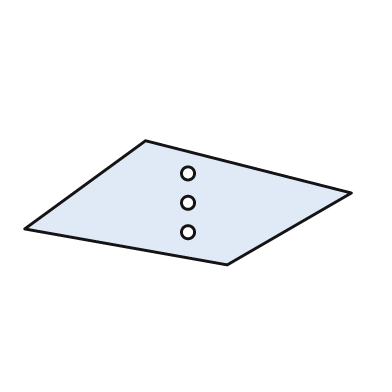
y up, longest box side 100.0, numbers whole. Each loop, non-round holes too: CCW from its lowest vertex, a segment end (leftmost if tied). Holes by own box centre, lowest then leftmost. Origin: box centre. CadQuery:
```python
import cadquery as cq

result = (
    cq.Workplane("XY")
    .moveTo(12.0, -19.0)
    .lineTo(50.0, 3.0)
    .lineTo(-13.0, 19.0)
    .lineTo(-50.0, -8.0)
    .close()
    .moveTo(0.0, -9.0)
    .circle(2.0)
    .moveTo(0.0, 0.0)
    .circle(2.0)
    .moveTo(0.0, 9.0)
    .circle(2.0)
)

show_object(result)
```